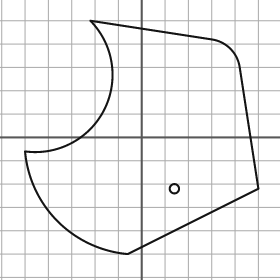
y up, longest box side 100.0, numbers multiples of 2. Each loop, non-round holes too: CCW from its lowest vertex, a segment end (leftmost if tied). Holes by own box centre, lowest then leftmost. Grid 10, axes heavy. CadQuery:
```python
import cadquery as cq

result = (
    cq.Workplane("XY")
    .moveTo(-6.0, -50.0)
    .lineTo(50.0, -22.0)
    .lineTo(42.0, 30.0)
    .threePointArc((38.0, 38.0), (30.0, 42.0))
    .lineTo(-22.0, 50.0)
    .threePointArc((-16.0, 12.0), (-50.0, -6.0))
    .threePointArc((-36.0, -36.0), (-6.0, -50.0))
    .close()
    .moveTo(14.0, -22.0)
    .circle(2.0)
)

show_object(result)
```